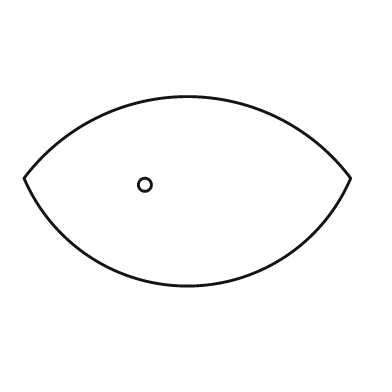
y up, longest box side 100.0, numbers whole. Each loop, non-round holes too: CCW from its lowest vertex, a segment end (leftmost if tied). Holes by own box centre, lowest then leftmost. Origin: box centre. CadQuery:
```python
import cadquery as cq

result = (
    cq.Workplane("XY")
    .moveTo(-50.0, 4.0)
    .threePointArc((0.0, -29.0), (50.0, 4.0))
    .threePointArc((0.0, 29.0), (-50.0, 4.0))
    .close()
    .moveTo(-13.0, 2.0)
    .circle(2.0)
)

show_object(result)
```